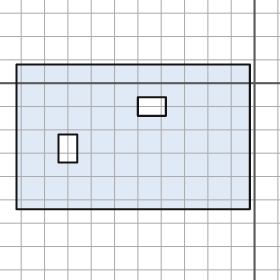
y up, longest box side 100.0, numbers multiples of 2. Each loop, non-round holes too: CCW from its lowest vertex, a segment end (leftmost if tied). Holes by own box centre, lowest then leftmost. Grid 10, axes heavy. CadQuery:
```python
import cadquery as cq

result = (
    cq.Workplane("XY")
    .moveTo(-102.0, -54.0)
    .lineTo(-2.0, -54.0)
    .lineTo(-2.0, 8.0)
    .lineTo(-102.0, 8.0)
    .close()
    .moveTo(-84.0, -34.0)
    .lineTo(-76.0, -34.0)
    .lineTo(-76.0, -22.0)
    .lineTo(-84.0, -22.0)
    .close()
    .moveTo(-50.0, -14.0)
    .lineTo(-38.0, -14.0)
    .lineTo(-38.0, -6.0)
    .lineTo(-50.0, -6.0)
    .close()
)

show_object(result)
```